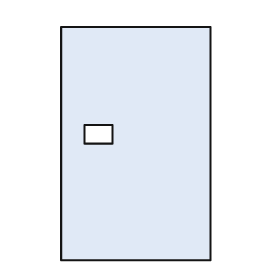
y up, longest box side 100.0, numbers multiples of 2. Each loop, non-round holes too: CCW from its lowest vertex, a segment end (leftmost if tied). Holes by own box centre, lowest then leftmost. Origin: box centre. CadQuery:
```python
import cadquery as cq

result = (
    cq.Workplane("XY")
    .moveTo(-32.0, -50.0)
    .lineTo(32.0, -50.0)
    .lineTo(32.0, 50.0)
    .lineTo(-32.0, 50.0)
    .close()
    .moveTo(-22.0, 0.0)
    .lineTo(-10.0, 0.0)
    .lineTo(-10.0, 8.0)
    .lineTo(-22.0, 8.0)
    .close()
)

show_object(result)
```